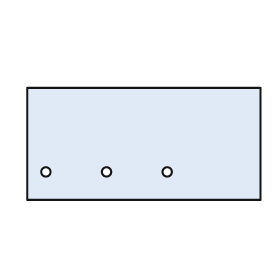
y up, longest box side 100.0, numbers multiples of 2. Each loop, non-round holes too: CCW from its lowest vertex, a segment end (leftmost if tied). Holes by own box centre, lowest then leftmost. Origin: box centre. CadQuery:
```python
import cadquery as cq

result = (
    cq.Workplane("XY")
    .moveTo(-50.0, -24.0)
    .lineTo(50.0, -24.0)
    .lineTo(50.0, 24.0)
    .lineTo(-50.0, 24.0)
    .close()
    .moveTo(-42.0, -12.0)
    .circle(2.0)
    .moveTo(-16.0, -12.0)
    .circle(2.0)
    .moveTo(10.0, -12.0)
    .circle(2.0)
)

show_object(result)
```